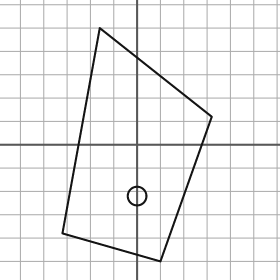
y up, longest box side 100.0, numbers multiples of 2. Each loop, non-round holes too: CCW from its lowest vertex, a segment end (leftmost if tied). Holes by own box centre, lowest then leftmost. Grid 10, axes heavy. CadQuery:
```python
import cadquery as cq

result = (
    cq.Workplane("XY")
    .moveTo(10.0, -50.0)
    .lineTo(32.0, 12.0)
    .lineTo(-16.0, 50.0)
    .lineTo(-32.0, -38.0)
    .close()
    .moveTo(0.0, -22.0)
    .circle(4.0)
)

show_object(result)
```